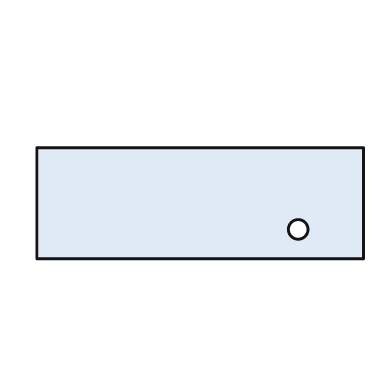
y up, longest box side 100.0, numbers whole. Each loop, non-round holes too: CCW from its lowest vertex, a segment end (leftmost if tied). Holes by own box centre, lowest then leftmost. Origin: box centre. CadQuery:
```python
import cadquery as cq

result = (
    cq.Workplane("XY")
    .moveTo(-50.0, -17.0)
    .lineTo(50.0, -17.0)
    .lineTo(50.0, 17.0)
    .lineTo(-50.0, 17.0)
    .close()
    .moveTo(30.0, -8.0)
    .circle(3.0)
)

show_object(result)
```